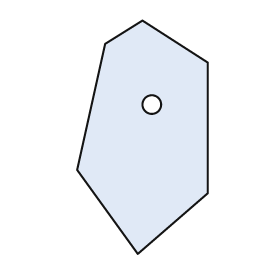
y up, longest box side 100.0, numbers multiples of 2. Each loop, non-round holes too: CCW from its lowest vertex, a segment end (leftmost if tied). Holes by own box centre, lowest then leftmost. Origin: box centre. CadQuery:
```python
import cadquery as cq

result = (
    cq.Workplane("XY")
    .moveTo(-2.0, -50.0)
    .lineTo(28.0, -24.0)
    .lineTo(28.0, 32.0)
    .lineTo(0.0, 50.0)
    .lineTo(-16.0, 40.0)
    .lineTo(-28.0, -14.0)
    .close()
    .moveTo(4.0, 14.0)
    .circle(4.0)
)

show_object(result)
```